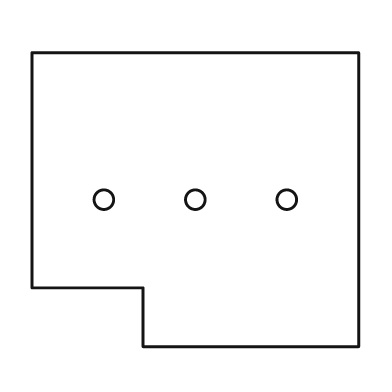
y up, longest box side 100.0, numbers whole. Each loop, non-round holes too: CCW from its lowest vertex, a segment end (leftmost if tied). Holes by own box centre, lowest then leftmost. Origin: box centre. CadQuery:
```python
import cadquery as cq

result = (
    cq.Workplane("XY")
    .moveTo(-16.0, -45.0)
    .lineTo(50.0, -45.0)
    .lineTo(50.0, 45.0)
    .lineTo(-50.0, 45.0)
    .lineTo(-50.0, -27.0)
    .lineTo(-16.0, -27.0)
    .close()
    .moveTo(-28.0, 0.0)
    .circle(3.0)
    .moveTo(0.0, 0.0)
    .circle(3.0)
    .moveTo(28.0, 0.0)
    .circle(3.0)
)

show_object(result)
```